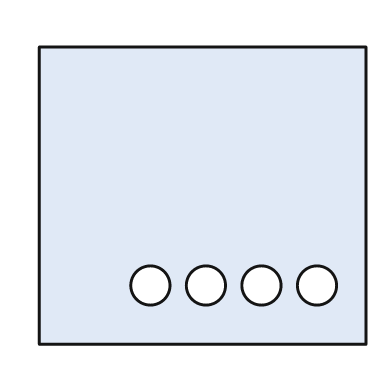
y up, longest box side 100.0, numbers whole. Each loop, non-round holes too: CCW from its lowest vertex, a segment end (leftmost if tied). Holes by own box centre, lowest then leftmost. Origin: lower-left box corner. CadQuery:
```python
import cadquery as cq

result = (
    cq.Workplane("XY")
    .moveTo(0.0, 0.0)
    .lineTo(100.0, 0.0)
    .lineTo(100.0, 91.0)
    .lineTo(0.0, 91.0)
    .close()
    .moveTo(34.0, 18.0)
    .circle(6.0)
    .moveTo(51.0, 18.0)
    .circle(6.0)
    .moveTo(68.0, 18.0)
    .circle(6.0)
    .moveTo(85.0, 18.0)
    .circle(6.0)
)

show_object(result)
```